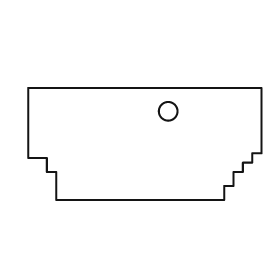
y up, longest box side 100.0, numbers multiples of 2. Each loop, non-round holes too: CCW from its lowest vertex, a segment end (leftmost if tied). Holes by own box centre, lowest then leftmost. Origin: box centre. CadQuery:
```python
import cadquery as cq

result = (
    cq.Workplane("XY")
    .moveTo(-38.0, -24.0)
    .lineTo(34.0, -24.0)
    .lineTo(34.0, -18.0)
    .lineTo(38.0, -18.0)
    .lineTo(38.0, -12.0)
    .lineTo(42.0, -12.0)
    .lineTo(42.0, -8.0)
    .lineTo(46.0, -8.0)
    .lineTo(46.0, -4.0)
    .lineTo(50.0, -4.0)
    .lineTo(50.0, 24.0)
    .lineTo(-50.0, 24.0)
    .lineTo(-50.0, -6.0)
    .lineTo(-42.0, -6.0)
    .lineTo(-42.0, -12.0)
    .lineTo(-38.0, -12.0)
    .close()
    .moveTo(10.0, 14.0)
    .circle(4.0)
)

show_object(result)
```